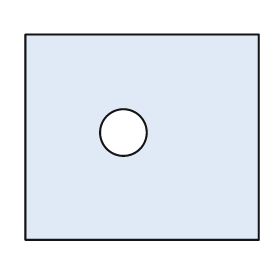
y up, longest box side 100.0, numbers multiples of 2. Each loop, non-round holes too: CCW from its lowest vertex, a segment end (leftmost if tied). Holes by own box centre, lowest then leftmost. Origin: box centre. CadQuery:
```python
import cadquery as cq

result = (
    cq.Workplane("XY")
    .moveTo(-50.0, -44.0)
    .lineTo(50.0, -44.0)
    .lineTo(50.0, 44.0)
    .lineTo(-50.0, 44.0)
    .close()
    .moveTo(-8.0, 2.0)
    .circle(10.0)
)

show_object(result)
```